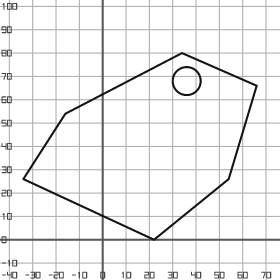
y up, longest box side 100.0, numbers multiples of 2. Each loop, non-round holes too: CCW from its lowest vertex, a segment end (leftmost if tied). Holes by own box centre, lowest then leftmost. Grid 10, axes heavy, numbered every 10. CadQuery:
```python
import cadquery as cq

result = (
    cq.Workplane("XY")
    .moveTo(22.0, 0.0)
    .lineTo(54.0, 26.0)
    .lineTo(66.0, 66.0)
    .lineTo(34.0, 80.0)
    .lineTo(-16.0, 54.0)
    .lineTo(-34.0, 26.0)
    .close()
    .moveTo(36.0, 68.0)
    .circle(6.0)
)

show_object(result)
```